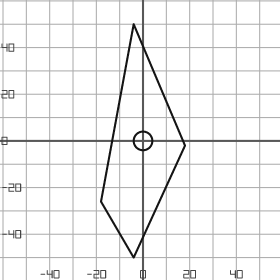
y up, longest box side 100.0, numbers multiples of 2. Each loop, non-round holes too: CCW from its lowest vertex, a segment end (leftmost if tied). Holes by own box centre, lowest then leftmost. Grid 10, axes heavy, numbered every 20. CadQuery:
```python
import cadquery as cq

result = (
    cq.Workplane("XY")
    .moveTo(-4.0, -50.0)
    .lineTo(18.0, -2.0)
    .lineTo(-4.0, 50.0)
    .lineTo(-18.0, -26.0)
    .close()
    .moveTo(0.0, 0.0)
    .circle(4.0)
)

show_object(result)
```